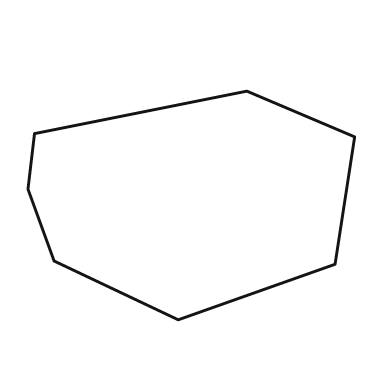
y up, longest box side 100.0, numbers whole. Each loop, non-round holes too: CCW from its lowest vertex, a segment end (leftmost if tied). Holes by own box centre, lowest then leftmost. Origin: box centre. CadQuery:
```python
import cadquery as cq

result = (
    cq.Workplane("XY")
    .moveTo(-4.0, -35.0)
    .lineTo(44.0, -18.0)
    .lineTo(50.0, 21.0)
    .lineTo(17.0, 35.0)
    .lineTo(-48.0, 22.0)
    .lineTo(-50.0, 5.0)
    .lineTo(-42.0, -17.0)
    .close()
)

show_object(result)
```